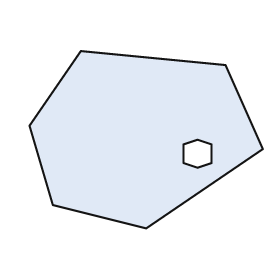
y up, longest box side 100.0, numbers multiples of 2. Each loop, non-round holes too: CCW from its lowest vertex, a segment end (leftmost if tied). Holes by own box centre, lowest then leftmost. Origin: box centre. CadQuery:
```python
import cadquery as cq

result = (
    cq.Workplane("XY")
    .moveTo(0.0, -38.0)
    .lineTo(50.0, -4.0)
    .lineTo(34.0, 32.0)
    .lineTo(-28.0, 38.0)
    .lineTo(-50.0, 6.0)
    .lineTo(-40.0, -28.0)
    .close()
    .moveTo(22.0, -12.0)
    .lineTo(28.0, -10.0)
    .lineTo(28.0, -2.0)
    .lineTo(22.0, 0.0)
    .lineTo(16.0, -2.0)
    .lineTo(16.0, -10.0)
    .close()
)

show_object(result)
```